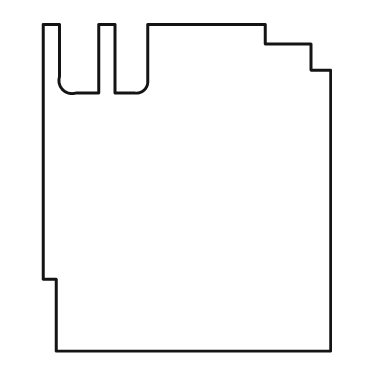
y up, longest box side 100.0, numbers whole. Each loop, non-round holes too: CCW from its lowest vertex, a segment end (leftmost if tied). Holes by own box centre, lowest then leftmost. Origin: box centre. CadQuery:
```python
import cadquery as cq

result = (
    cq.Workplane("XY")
    .moveTo(-40.0, -50.0)
    .lineTo(44.0, -50.0)
    .lineTo(44.0, 36.0)
    .lineTo(38.0, 36.0)
    .lineTo(38.0, 44.0)
    .lineTo(24.0, 44.0)
    .lineTo(24.0, 50.0)
    .lineTo(-12.0, 50.0)
    .lineTo(-12.0, 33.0)
    .threePointArc((-13.0, 30.0), (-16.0, 29.0))
    .lineTo(-22.0, 29.0)
    .lineTo(-22.0, 50.0)
    .lineTo(-27.0, 50.0)
    .lineTo(-27.0, 29.0)
    .lineTo(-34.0, 29.0)
    .threePointArc((-38.0, 30.0), (-39.0, 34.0))
    .lineTo(-39.0, 50.0)
    .lineTo(-44.0, 50.0)
    .lineTo(-44.0, -28.0)
    .lineTo(-40.0, -28.0)
    .close()
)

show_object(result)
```